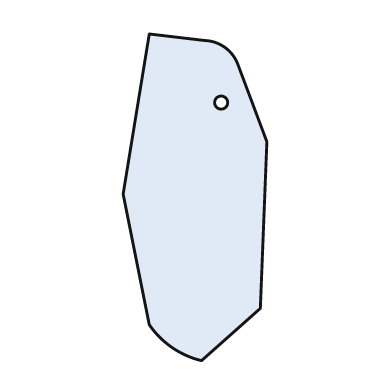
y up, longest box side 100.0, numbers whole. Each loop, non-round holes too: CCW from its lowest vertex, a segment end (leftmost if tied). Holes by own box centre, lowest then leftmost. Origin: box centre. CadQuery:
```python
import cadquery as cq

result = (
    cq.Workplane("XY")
    .moveTo(2.0, -50.0)
    .lineTo(20.0, -34.0)
    .lineTo(22.0, 17.0)
    .lineTo(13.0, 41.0)
    .threePointArc((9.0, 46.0), (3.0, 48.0))
    .lineTo(-14.0, 50.0)
    .lineTo(-22.0, 1.0)
    .lineTo(-14.0, -39.0)
    .threePointArc((-7.0, -46.0), (2.0, -50.0))
    .close()
    .moveTo(8.0, 29.0)
    .circle(2.0)
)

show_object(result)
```